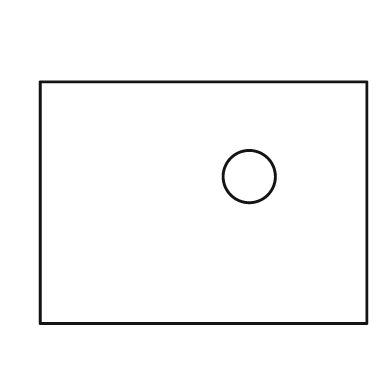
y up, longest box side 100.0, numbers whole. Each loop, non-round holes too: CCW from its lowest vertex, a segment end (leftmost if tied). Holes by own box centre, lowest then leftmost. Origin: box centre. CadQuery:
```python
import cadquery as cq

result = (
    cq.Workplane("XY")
    .moveTo(-50.0, -37.0)
    .lineTo(50.0, -37.0)
    .lineTo(50.0, 37.0)
    .lineTo(-50.0, 37.0)
    .close()
    .moveTo(14.0, 8.0)
    .circle(8.0)
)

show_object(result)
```